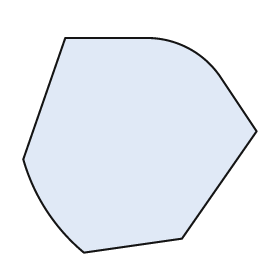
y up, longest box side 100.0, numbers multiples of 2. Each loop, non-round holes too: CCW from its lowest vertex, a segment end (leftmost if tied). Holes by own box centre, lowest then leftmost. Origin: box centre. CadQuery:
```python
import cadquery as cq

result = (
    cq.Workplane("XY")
    .moveTo(-24.0, -46.0)
    .lineTo(18.0, -40.0)
    .lineTo(50.0, 6.0)
    .lineTo(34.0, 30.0)
    .threePointArc((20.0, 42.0), (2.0, 46.0))
    .lineTo(-32.0, 46.0)
    .lineTo(-50.0, -6.0)
    .threePointArc((-40.0, -28.0), (-24.0, -46.0))
    .close()
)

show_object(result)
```